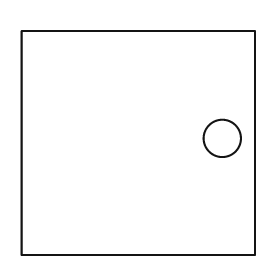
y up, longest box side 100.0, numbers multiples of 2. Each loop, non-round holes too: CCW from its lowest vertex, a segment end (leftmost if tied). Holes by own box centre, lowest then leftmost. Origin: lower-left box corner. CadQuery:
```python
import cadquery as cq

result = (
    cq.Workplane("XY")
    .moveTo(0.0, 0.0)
    .lineTo(100.0, 0.0)
    .lineTo(100.0, 96.0)
    .lineTo(0.0, 96.0)
    .close()
    .moveTo(86.0, 50.0)
    .circle(8.0)
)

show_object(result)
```